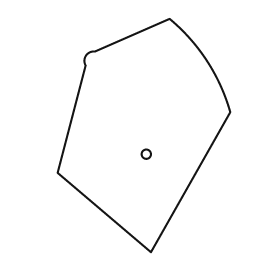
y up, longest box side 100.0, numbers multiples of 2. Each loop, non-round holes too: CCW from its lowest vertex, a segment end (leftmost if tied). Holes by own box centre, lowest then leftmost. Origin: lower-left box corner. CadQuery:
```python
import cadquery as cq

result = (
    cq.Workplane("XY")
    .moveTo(40.0, 0.0)
    .lineTo(74.0, 60.0)
    .threePointArc((64.0, 82.0), (48.0, 100.0))
    .lineTo(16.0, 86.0)
    .threePointArc((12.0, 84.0), (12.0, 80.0))
    .lineTo(0.0, 34.0)
    .close()
    .moveTo(38.0, 42.0)
    .circle(2.0)
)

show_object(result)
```